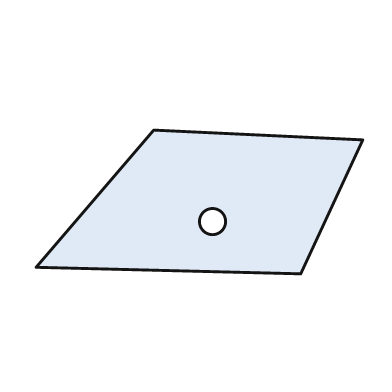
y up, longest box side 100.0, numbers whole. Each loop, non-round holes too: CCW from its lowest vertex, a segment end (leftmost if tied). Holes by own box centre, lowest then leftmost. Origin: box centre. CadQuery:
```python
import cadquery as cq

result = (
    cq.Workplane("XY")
    .moveTo(31.0, -22.0)
    .lineTo(50.0, 19.0)
    .lineTo(-14.0, 22.0)
    .lineTo(-50.0, -20.0)
    .close()
    .moveTo(4.0, -6.0)
    .circle(4.0)
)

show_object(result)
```